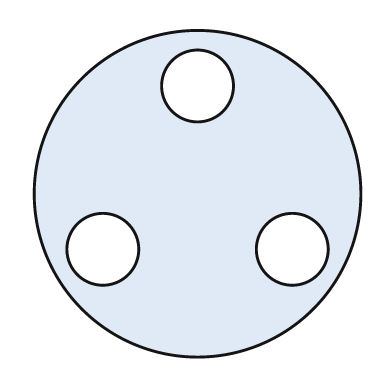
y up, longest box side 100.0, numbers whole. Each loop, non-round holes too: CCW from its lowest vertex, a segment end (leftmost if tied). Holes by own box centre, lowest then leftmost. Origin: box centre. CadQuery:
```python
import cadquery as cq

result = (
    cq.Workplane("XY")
    .moveTo(0.0, 0.0)
    .circle(50.0)
    .moveTo(-29.0, -17.0)
    .circle(11.0)
    .moveTo(29.0, -17.0)
    .circle(11.0)
    .moveTo(0.0, 33.0)
    .circle(11.0)
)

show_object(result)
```